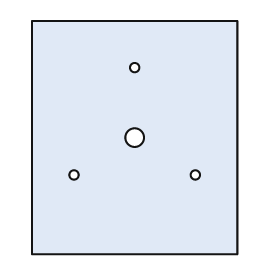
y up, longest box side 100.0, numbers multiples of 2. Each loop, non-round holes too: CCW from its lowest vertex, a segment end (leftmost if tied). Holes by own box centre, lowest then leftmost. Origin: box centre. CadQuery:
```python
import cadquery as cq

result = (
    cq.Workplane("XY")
    .moveTo(-44.0, -50.0)
    .lineTo(44.0, -50.0)
    .lineTo(44.0, 50.0)
    .lineTo(-44.0, 50.0)
    .close()
    .moveTo(-26.0, -16.0)
    .circle(2.0)
    .moveTo(26.0, -16.0)
    .circle(2.0)
    .moveTo(0.0, 0.0)
    .circle(4.0)
    .moveTo(0.0, 30.0)
    .circle(2.0)
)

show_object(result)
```